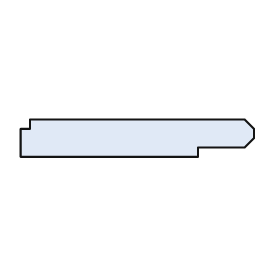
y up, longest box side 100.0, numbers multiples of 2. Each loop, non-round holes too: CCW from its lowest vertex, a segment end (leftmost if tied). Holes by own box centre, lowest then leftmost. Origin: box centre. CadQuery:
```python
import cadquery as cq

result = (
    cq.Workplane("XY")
    .moveTo(-50.0, -8.0)
    .lineTo(26.0, -8.0)
    .lineTo(26.0, -4.0)
    .lineTo(46.0, -4.0)
    .lineTo(50.0, 0.0)
    .lineTo(50.0, 4.0)
    .lineTo(46.0, 8.0)
    .lineTo(-46.0, 8.0)
    .lineTo(-46.0, 4.0)
    .lineTo(-50.0, 4.0)
    .close()
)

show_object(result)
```